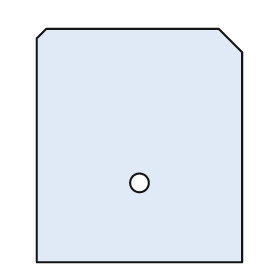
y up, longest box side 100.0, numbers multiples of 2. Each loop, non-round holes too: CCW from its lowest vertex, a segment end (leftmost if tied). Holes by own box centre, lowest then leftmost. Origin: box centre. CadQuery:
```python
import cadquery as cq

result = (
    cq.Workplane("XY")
    .moveTo(-44.0, -50.0)
    .lineTo(44.0, -50.0)
    .lineTo(44.0, 40.0)
    .lineTo(34.0, 50.0)
    .lineTo(-40.0, 50.0)
    .lineTo(-44.0, 46.0)
    .close()
    .moveTo(0.0, -16.0)
    .circle(4.0)
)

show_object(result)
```